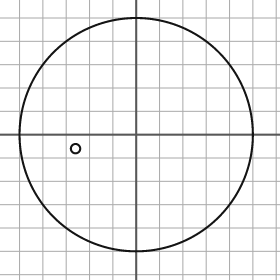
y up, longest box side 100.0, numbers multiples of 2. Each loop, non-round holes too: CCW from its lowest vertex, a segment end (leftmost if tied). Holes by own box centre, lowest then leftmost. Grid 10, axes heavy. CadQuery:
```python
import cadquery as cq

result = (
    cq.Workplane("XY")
    .moveTo(0.0, 0.0)
    .circle(50.0)
    .moveTo(-26.0, -6.0)
    .circle(2.0)
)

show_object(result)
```